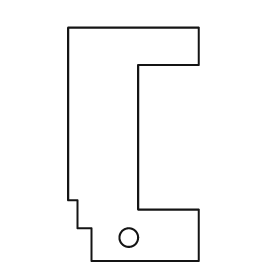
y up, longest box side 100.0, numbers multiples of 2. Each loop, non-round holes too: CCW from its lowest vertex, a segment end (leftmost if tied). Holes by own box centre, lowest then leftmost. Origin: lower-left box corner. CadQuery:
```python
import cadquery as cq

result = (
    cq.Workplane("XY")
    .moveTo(10.0, 0.0)
    .lineTo(56.0, 0.0)
    .lineTo(56.0, 22.0)
    .lineTo(30.0, 22.0)
    .lineTo(30.0, 84.0)
    .lineTo(56.0, 84.0)
    .lineTo(56.0, 100.0)
    .lineTo(0.0, 100.0)
    .lineTo(0.0, 26.0)
    .lineTo(4.0, 26.0)
    .lineTo(4.0, 14.0)
    .lineTo(10.0, 14.0)
    .close()
    .moveTo(26.0, 10.0)
    .circle(4.0)
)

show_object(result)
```